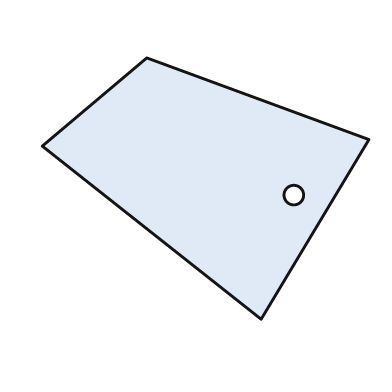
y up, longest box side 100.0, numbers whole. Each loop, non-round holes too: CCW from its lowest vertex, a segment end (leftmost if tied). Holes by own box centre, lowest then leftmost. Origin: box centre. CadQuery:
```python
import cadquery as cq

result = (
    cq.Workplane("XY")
    .moveTo(17.0, -40.0)
    .lineTo(50.0, 15.0)
    .lineTo(-18.0, 40.0)
    .lineTo(-50.0, 13.0)
    .close()
    .moveTo(27.0, -2.0)
    .circle(3.0)
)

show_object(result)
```